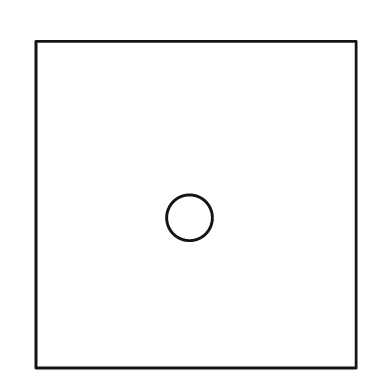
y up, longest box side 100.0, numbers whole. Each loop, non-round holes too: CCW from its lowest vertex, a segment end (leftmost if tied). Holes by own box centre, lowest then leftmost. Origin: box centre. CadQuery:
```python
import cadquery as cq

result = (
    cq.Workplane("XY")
    .moveTo(-49.0, -50.0)
    .lineTo(49.0, -50.0)
    .lineTo(49.0, 50.0)
    .lineTo(-49.0, 50.0)
    .close()
    .moveTo(-2.0, -4.0)
    .circle(7.0)
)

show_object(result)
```